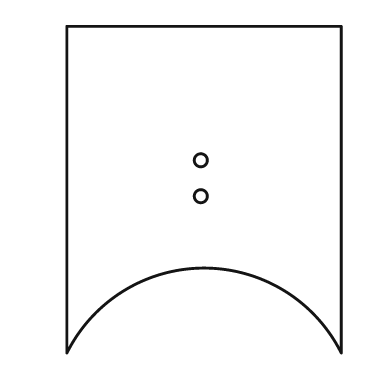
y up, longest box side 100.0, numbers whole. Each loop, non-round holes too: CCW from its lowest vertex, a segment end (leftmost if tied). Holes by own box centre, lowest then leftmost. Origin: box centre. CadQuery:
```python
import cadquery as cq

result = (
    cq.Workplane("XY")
    .moveTo(-42.0, -50.0)
    .threePointArc((0.0, -24.0), (42.0, -50.0))
    .lineTo(42.0, 50.0)
    .lineTo(-42.0, 50.0)
    .close()
    .moveTo(-1.0, -2.0)
    .circle(2.0)
    .moveTo(-1.0, 9.0)
    .circle(2.0)
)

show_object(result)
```